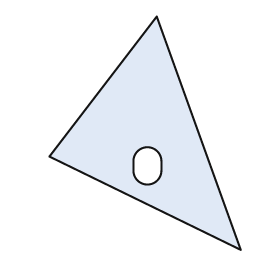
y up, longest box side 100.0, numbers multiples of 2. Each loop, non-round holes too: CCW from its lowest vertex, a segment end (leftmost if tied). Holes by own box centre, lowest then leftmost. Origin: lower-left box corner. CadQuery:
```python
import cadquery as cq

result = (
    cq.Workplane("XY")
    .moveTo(82.0, 0.0)
    .lineTo(46.0, 100.0)
    .lineTo(0.0, 40.0)
    .close()
    .moveTo(36.0, 34.0)
    .threePointArc((42.0, 28.0), (48.0, 34.0))
    .lineTo(48.0, 38.0)
    .threePointArc((42.0, 44.0), (36.0, 38.0))
    .close()
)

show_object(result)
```